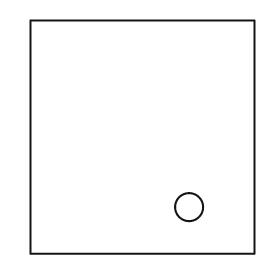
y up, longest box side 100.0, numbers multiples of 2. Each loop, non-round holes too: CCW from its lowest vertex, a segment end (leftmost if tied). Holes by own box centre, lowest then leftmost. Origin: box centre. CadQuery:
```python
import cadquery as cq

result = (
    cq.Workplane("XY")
    .moveTo(-48.0, -50.0)
    .lineTo(48.0, -50.0)
    .lineTo(48.0, 50.0)
    .lineTo(-48.0, 50.0)
    .close()
    .moveTo(20.0, -30.0)
    .circle(6.0)
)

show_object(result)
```